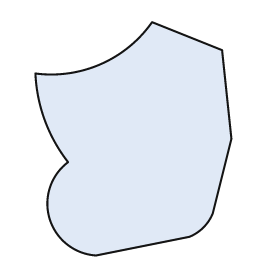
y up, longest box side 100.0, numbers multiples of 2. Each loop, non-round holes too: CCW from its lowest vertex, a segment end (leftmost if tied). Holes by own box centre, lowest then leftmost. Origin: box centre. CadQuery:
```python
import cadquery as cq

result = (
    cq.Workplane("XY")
    .moveTo(-16.0, -50.0)
    .lineTo(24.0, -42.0)
    .threePointArc((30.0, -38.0), (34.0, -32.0))
    .lineTo(42.0, 0.0)
    .lineTo(38.0, 38.0)
    .lineTo(8.0, 50.0)
    .threePointArc((-14.0, 32.0), (-42.0, 28.0))
    .threePointArc((-38.0, 8.0), (-28.0, -10.0))
    .threePointArc((-36.0, -34.0), (-16.0, -50.0))
    .close()
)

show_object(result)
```